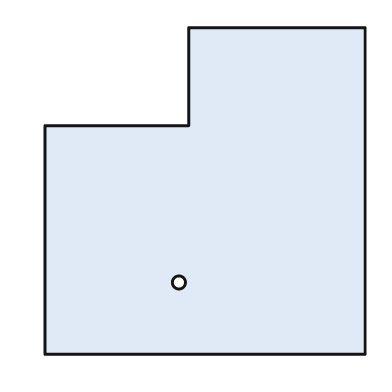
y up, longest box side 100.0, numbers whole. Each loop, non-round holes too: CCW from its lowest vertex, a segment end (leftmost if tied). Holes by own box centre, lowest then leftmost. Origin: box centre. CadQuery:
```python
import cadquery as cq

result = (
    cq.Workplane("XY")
    .moveTo(-49.0, -50.0)
    .lineTo(49.0, -50.0)
    .lineTo(49.0, 50.0)
    .lineTo(-5.0, 50.0)
    .lineTo(-5.0, 20.0)
    .lineTo(-49.0, 20.0)
    .close()
    .moveTo(-8.0, -28.0)
    .circle(2.0)
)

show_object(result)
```